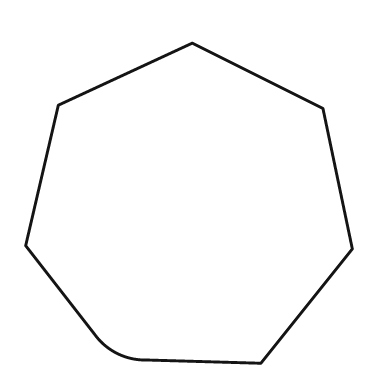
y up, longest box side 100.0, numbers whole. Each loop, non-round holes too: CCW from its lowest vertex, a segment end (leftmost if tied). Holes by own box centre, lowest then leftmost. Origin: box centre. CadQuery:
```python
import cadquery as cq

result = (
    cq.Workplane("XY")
    .moveTo(22.0, -49.0)
    .lineTo(50.0, -14.0)
    .lineTo(41.0, 29.0)
    .lineTo(1.0, 49.0)
    .lineTo(-40.0, 30.0)
    .lineTo(-50.0, -13.0)
    .lineTo(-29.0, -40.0)
    .threePointArc((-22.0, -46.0), (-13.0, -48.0))
    .close()
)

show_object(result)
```